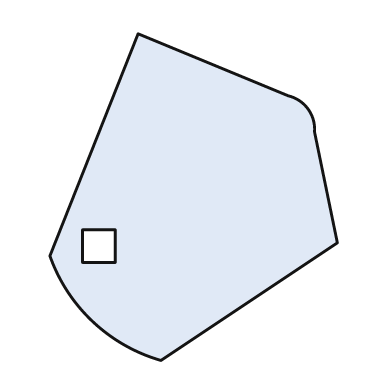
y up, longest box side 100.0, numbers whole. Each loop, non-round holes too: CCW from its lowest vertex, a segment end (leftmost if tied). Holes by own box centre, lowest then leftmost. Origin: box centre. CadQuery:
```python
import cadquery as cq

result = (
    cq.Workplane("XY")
    .moveTo(-10.0, -50.0)
    .lineTo(44.0, -14.0)
    .lineTo(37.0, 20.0)
    .threePointArc((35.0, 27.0), (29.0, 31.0))
    .lineTo(-17.0, 50.0)
    .lineTo(-44.0, -18.0)
    .threePointArc((-31.0, -38.0), (-10.0, -50.0))
    .close()
    .moveTo(-34.0, -20.0)
    .lineTo(-24.0, -20.0)
    .lineTo(-24.0, -10.0)
    .lineTo(-34.0, -10.0)
    .close()
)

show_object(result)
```